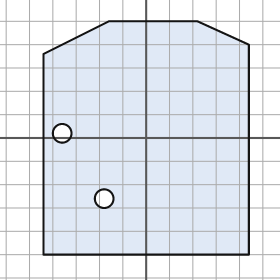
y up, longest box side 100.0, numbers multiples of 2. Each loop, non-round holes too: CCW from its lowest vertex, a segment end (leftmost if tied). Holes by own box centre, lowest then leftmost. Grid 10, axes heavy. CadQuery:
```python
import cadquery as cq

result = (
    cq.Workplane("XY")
    .moveTo(-44.0, -50.0)
    .lineTo(44.0, -50.0)
    .lineTo(44.0, 40.0)
    .lineTo(22.0, 50.0)
    .lineTo(-16.0, 50.0)
    .lineTo(-44.0, 36.0)
    .close()
    .moveTo(-18.0, -26.0)
    .circle(4.0)
    .moveTo(-36.0, 2.0)
    .circle(4.0)
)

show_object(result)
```